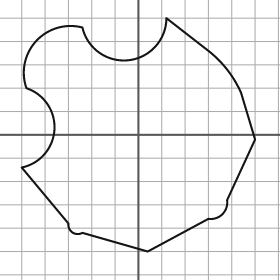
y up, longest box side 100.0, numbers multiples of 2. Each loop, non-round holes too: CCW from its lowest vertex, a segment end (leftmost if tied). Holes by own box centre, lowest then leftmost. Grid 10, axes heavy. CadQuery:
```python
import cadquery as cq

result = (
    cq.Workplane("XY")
    .moveTo(4.0, -50.0)
    .lineTo(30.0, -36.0)
    .threePointArc((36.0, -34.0), (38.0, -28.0))
    .lineTo(50.0, -2.0)
    .lineTo(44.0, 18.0)
    .threePointArc((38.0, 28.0), (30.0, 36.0))
    .lineTo(12.0, 50.0)
    .threePointArc((-4.0, 32.0), (-24.0, 46.0))
    .threePointArc((-44.0, 40.0), (-48.0, 20.0))
    .threePointArc((-36.0, 2.0), (-50.0, -14.0))
    .lineTo(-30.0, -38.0)
    .threePointArc((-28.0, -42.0), (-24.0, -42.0))
    .close()
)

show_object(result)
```